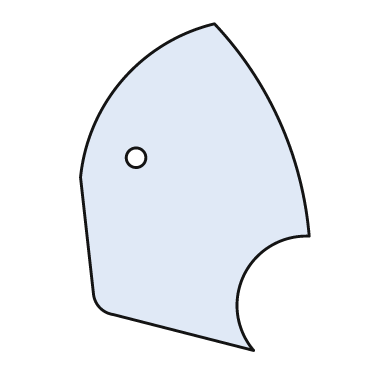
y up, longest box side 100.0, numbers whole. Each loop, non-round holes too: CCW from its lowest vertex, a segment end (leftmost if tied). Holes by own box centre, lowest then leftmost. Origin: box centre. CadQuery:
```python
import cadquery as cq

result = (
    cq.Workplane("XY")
    .moveTo(18.0, -50.0)
    .threePointArc((15.0, -27.0), (35.0, -15.0))
    .threePointArc((26.0, 20.0), (6.0, 50.0))
    .threePointArc((-22.0, 33.0), (-35.0, 3.0))
    .lineTo(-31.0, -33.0)
    .threePointArc((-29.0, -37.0), (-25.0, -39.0))
    .close()
    .moveTo(-18.0, 9.0)
    .circle(3.0)
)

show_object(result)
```